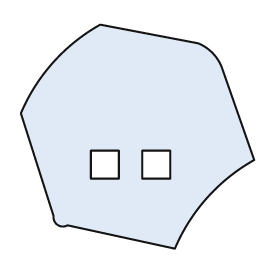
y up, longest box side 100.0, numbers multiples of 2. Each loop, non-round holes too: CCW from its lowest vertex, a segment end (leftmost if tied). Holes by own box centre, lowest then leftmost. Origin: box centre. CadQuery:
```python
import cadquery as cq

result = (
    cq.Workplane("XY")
    .moveTo(16.0, -48.0)
    .threePointArc((30.0, -26.0), (50.0, -10.0))
    .lineTo(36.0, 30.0)
    .threePointArc((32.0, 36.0), (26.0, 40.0))
    .lineTo(-16.0, 48.0)
    .threePointArc((-36.0, 32.0), (-50.0, 10.0))
    .lineTo(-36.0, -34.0)
    .threePointArc((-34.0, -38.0), (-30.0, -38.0))
    .close()
    .moveTo(-20.0, -18.0)
    .lineTo(-8.0, -18.0)
    .lineTo(-8.0, -6.0)
    .lineTo(-20.0, -6.0)
    .close()
    .moveTo(2.0, -18.0)
    .lineTo(14.0, -18.0)
    .lineTo(14.0, -6.0)
    .lineTo(2.0, -6.0)
    .close()
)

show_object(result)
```